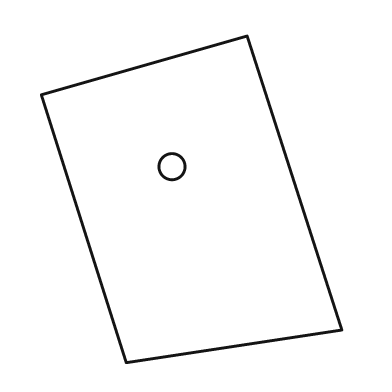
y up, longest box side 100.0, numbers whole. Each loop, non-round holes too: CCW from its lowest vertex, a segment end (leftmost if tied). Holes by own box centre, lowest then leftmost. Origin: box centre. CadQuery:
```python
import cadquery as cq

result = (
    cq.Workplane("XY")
    .moveTo(-20.0, -50.0)
    .lineTo(46.0, -40.0)
    .lineTo(17.0, 50.0)
    .lineTo(-46.0, 32.0)
    .close()
    .moveTo(-6.0, 10.0)
    .circle(4.0)
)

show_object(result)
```